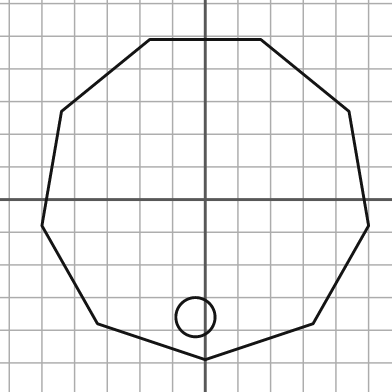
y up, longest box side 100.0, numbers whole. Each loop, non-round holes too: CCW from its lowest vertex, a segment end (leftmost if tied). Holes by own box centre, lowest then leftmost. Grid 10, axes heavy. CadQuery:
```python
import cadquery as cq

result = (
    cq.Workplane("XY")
    .moveTo(0.0, -49.0)
    .lineTo(33.0, -38.0)
    .lineTo(50.0, -8.0)
    .lineTo(44.0, 27.0)
    .lineTo(17.0, 49.0)
    .lineTo(-17.0, 49.0)
    .lineTo(-44.0, 27.0)
    .lineTo(-50.0, -8.0)
    .lineTo(-33.0, -38.0)
    .close()
    .moveTo(-3.0, -36.0)
    .circle(6.0)
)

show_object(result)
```